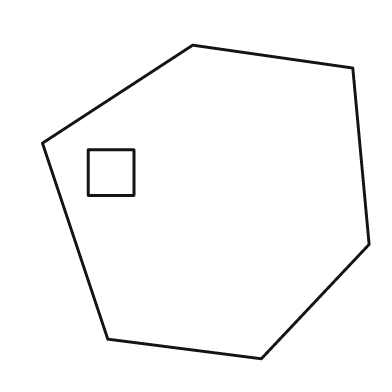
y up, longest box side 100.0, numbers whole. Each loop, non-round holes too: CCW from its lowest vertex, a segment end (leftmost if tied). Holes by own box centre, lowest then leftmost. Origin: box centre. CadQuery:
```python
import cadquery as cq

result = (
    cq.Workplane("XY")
    .moveTo(17.0, -48.0)
    .lineTo(50.0, -13.0)
    .lineTo(45.0, 41.0)
    .lineTo(-4.0, 48.0)
    .lineTo(-50.0, 18.0)
    .lineTo(-30.0, -42.0)
    .close()
    .moveTo(-36.0, 2.0)
    .lineTo(-22.0, 2.0)
    .lineTo(-22.0, 16.0)
    .lineTo(-36.0, 16.0)
    .close()
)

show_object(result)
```